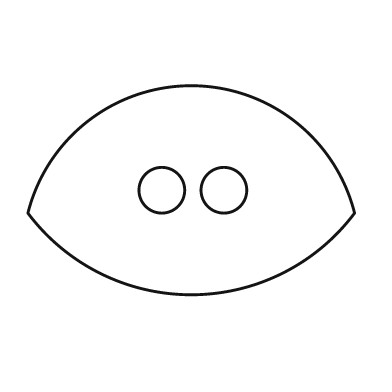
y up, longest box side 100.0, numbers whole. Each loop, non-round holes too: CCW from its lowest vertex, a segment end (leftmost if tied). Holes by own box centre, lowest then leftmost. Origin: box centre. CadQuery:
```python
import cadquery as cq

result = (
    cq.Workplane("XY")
    .moveTo(-50.0, -7.0)
    .threePointArc((0.0, -32.0), (50.0, -7.0))
    .threePointArc((0.0, 32.0), (-50.0, -7.0))
    .close()
    .moveTo(-9.0, 0.0)
    .circle(7.0)
    .moveTo(10.0, 0.0)
    .circle(7.0)
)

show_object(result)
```